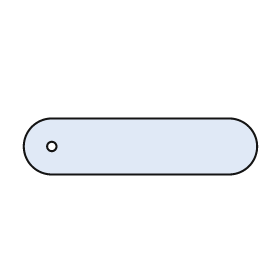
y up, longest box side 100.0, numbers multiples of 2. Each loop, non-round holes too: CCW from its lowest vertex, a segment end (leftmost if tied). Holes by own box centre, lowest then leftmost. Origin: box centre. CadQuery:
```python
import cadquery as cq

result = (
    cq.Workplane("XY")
    .moveTo(-38.0, -12.0)
    .lineTo(38.0, -12.0)
    .threePointArc((50.0, 0.0), (38.0, 12.0))
    .lineTo(-38.0, 12.0)
    .threePointArc((-50.0, 0.0), (-38.0, -12.0))
    .close()
    .moveTo(-38.0, 0.0)
    .circle(2.0)
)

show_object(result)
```